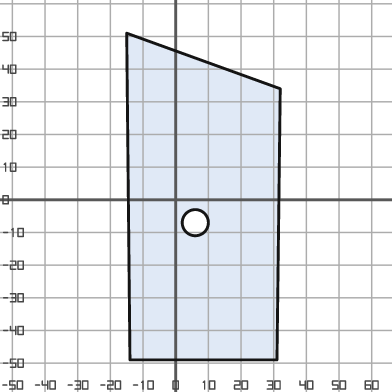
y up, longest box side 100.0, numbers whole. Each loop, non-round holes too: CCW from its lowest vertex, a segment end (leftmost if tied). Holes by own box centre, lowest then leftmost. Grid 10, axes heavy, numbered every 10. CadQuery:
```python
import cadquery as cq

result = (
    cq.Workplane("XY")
    .moveTo(-14.0, -49.0)
    .lineTo(31.0, -49.0)
    .lineTo(32.0, 34.0)
    .lineTo(-15.0, 51.0)
    .close()
    .moveTo(6.0, -7.0)
    .circle(4.0)
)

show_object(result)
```